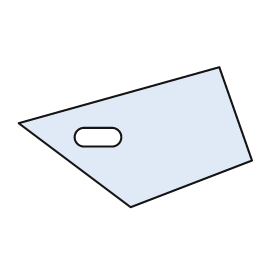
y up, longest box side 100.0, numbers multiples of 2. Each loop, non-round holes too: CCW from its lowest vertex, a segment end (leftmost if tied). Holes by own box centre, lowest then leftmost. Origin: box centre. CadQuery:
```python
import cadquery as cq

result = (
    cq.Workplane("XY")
    .moveTo(-2.0, -30.0)
    .lineTo(50.0, -10.0)
    .lineTo(36.0, 30.0)
    .lineTo(-50.0, 6.0)
    .close()
    .moveTo(-22.0, -4.0)
    .lineTo(-10.0, -4.0)
    .threePointArc((-6.0, 0.0), (-10.0, 4.0))
    .lineTo(-22.0, 4.0)
    .threePointArc((-26.0, 0.0), (-22.0, -4.0))
    .close()
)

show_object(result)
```